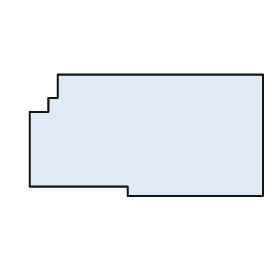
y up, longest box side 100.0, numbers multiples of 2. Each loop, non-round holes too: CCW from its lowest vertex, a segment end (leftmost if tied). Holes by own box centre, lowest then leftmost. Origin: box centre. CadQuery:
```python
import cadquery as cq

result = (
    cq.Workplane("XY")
    .moveTo(-8.0, -26.0)
    .lineTo(50.0, -26.0)
    .lineTo(50.0, 26.0)
    .lineTo(-38.0, 26.0)
    .lineTo(-38.0, 16.0)
    .lineTo(-42.0, 16.0)
    .lineTo(-42.0, 10.0)
    .lineTo(-50.0, 10.0)
    .lineTo(-50.0, -22.0)
    .lineTo(-8.0, -22.0)
    .close()
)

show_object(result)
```